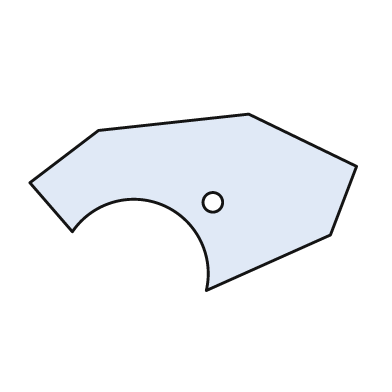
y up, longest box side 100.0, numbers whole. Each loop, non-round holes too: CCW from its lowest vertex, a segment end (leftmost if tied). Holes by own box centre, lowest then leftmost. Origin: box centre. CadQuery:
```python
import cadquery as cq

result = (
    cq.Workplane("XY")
    .moveTo(4.0, -27.0)
    .lineTo(42.0, -10.0)
    .lineTo(50.0, 11.0)
    .lineTo(17.0, 27.0)
    .lineTo(-29.0, 22.0)
    .lineTo(-50.0, 6.0)
    .lineTo(-37.0, -9.0)
    .threePointArc((-9.0, -1.0), (4.0, -27.0))
    .close()
    .moveTo(6.0, 0.0)
    .circle(3.0)
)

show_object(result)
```